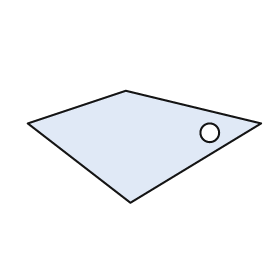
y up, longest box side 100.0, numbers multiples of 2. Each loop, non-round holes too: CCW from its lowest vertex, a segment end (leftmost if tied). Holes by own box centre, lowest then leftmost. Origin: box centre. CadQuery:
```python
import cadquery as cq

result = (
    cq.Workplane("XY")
    .moveTo(-6.0, -24.0)
    .lineTo(50.0, 10.0)
    .lineTo(-8.0, 24.0)
    .lineTo(-50.0, 10.0)
    .close()
    .moveTo(28.0, 6.0)
    .circle(4.0)
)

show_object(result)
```